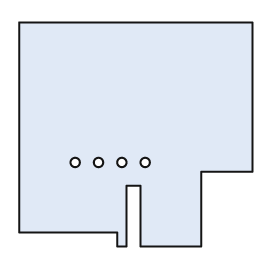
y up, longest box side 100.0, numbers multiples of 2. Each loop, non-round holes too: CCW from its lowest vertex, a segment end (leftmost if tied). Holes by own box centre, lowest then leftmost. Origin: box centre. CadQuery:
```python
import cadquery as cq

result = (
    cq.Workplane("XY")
    .moveTo(-8.0, -48.0)
    .lineTo(-4.0, -48.0)
    .lineTo(-4.0, -22.0)
    .lineTo(2.0, -22.0)
    .lineTo(2.0, -48.0)
    .lineTo(28.0, -48.0)
    .lineTo(28.0, -16.0)
    .lineTo(50.0, -16.0)
    .lineTo(50.0, 48.0)
    .lineTo(-50.0, 48.0)
    .lineTo(-50.0, -42.0)
    .lineTo(-8.0, -42.0)
    .close()
    .moveTo(-26.0, -12.0)
    .circle(2.0)
    .moveTo(-16.0, -12.0)
    .circle(2.0)
    .moveTo(-6.0, -12.0)
    .circle(2.0)
    .moveTo(4.0, -12.0)
    .circle(2.0)
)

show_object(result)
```